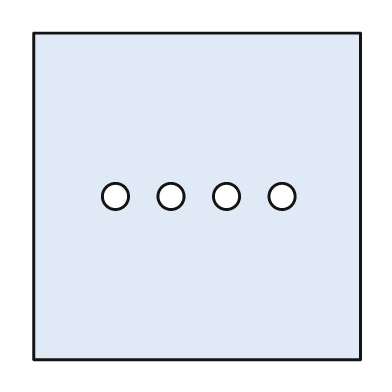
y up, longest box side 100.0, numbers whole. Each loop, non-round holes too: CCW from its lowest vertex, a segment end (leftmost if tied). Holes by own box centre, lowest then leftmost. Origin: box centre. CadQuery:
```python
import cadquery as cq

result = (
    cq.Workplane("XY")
    .moveTo(-50.0, -50.0)
    .lineTo(50.0, -50.0)
    .lineTo(50.0, 50.0)
    .lineTo(-50.0, 50.0)
    .close()
    .moveTo(-25.0, 0.0)
    .circle(4.0)
    .moveTo(-8.0, 0.0)
    .circle(4.0)
    .moveTo(9.0, 0.0)
    .circle(4.0)
    .moveTo(26.0, 0.0)
    .circle(4.0)
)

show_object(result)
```